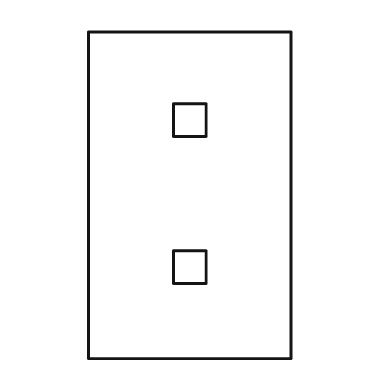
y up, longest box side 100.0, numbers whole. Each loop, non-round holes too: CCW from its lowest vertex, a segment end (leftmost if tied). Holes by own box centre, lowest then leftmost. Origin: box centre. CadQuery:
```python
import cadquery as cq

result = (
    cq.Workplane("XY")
    .moveTo(-31.0, -50.0)
    .lineTo(31.0, -50.0)
    .lineTo(31.0, 50.0)
    .lineTo(-31.0, 50.0)
    .close()
    .moveTo(-5.0, -27.0)
    .lineTo(5.0, -27.0)
    .lineTo(5.0, -17.0)
    .lineTo(-5.0, -17.0)
    .close()
    .moveTo(-5.0, 18.0)
    .lineTo(5.0, 18.0)
    .lineTo(5.0, 28.0)
    .lineTo(-5.0, 28.0)
    .close()
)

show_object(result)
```